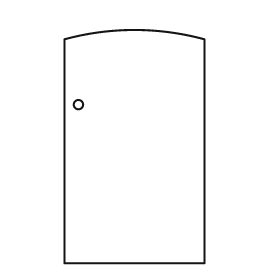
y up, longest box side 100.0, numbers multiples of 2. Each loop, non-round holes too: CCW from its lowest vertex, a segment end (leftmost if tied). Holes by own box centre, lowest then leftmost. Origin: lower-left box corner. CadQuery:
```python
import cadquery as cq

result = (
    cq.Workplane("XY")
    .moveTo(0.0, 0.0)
    .lineTo(60.0, 0.0)
    .lineTo(60.0, 96.0)
    .threePointArc((30.0, 100.0), (0.0, 96.0))
    .close()
    .moveTo(6.0, 68.0)
    .circle(2.0)
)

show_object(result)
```